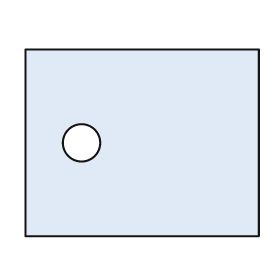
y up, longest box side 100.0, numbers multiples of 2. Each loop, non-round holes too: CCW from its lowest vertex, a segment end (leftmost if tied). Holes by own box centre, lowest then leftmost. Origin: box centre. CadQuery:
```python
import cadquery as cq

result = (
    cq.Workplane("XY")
    .moveTo(-50.0, -40.0)
    .lineTo(50.0, -40.0)
    .lineTo(50.0, 40.0)
    .lineTo(-50.0, 40.0)
    .close()
    .moveTo(-26.0, 0.0)
    .circle(8.0)
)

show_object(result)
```